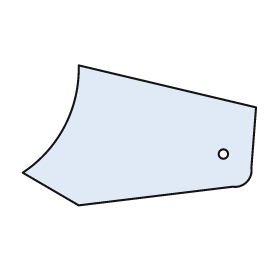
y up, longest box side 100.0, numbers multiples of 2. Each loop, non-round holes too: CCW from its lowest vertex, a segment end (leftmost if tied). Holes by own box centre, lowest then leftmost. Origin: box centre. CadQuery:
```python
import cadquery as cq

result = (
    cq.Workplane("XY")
    .moveTo(-26.0, -30.0)
    .lineTo(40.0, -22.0)
    .threePointArc((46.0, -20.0), (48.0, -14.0))
    .lineTo(50.0, 12.0)
    .lineTo(-26.0, 30.0)
    .threePointArc((-32.0, 4.0), (-50.0, -16.0))
    .close()
    .moveTo(36.0, -8.0)
    .circle(2.0)
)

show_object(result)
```